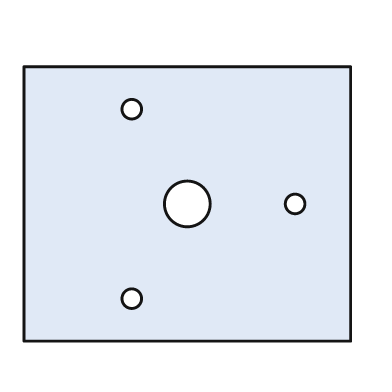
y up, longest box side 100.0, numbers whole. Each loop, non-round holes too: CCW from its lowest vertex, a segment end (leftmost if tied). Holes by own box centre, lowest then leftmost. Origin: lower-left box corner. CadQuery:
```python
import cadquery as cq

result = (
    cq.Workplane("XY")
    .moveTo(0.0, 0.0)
    .lineTo(100.0, 0.0)
    .lineTo(100.0, 84.0)
    .lineTo(0.0, 84.0)
    .close()
    .moveTo(33.0, 13.0)
    .circle(3.0)
    .moveTo(50.0, 42.0)
    .circle(7.0)
    .moveTo(83.0, 42.0)
    .circle(3.0)
    .moveTo(33.0, 71.0)
    .circle(3.0)
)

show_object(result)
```